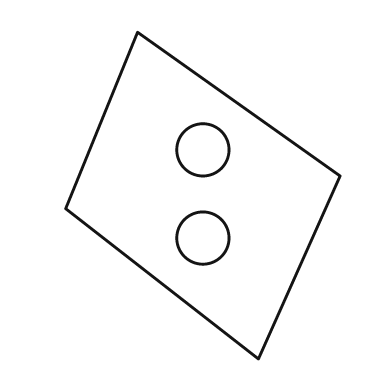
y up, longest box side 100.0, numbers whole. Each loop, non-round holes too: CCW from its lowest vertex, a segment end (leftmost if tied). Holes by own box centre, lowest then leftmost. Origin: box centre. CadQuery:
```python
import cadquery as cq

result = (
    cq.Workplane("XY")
    .moveTo(17.0, -50.0)
    .lineTo(42.0, 6.0)
    .lineTo(-20.0, 50.0)
    .lineTo(-42.0, -4.0)
    .close()
    .moveTo(0.0, -13.0)
    .circle(8.0)
    .moveTo(0.0, 14.0)
    .circle(8.0)
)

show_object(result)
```